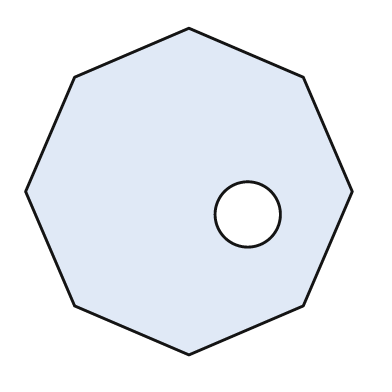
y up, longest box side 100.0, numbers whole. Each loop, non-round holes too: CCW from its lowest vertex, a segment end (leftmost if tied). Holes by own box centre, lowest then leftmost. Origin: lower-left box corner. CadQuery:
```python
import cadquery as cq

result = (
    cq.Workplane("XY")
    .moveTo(50.0, 0.0)
    .lineTo(85.0, 15.0)
    .lineTo(100.0, 50.0)
    .lineTo(85.0, 85.0)
    .lineTo(50.0, 100.0)
    .lineTo(15.0, 85.0)
    .lineTo(0.0, 50.0)
    .lineTo(15.0, 15.0)
    .close()
    .moveTo(68.0, 43.0)
    .circle(10.0)
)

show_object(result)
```